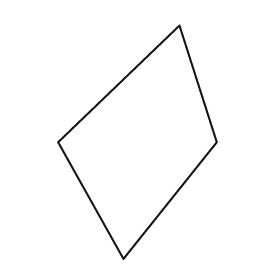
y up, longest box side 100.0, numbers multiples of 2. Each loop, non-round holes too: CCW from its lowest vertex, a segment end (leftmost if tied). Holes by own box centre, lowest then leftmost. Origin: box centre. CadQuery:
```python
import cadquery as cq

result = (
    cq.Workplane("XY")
    .moveTo(-6.0, -50.0)
    .lineTo(34.0, 0.0)
    .lineTo(18.0, 50.0)
    .lineTo(-34.0, 0.0)
    .close()
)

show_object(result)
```